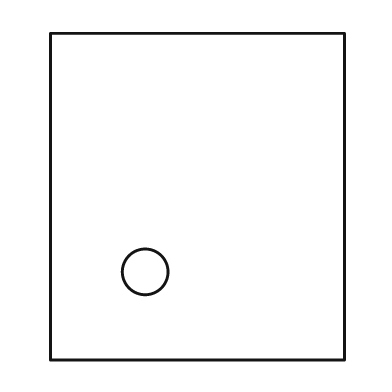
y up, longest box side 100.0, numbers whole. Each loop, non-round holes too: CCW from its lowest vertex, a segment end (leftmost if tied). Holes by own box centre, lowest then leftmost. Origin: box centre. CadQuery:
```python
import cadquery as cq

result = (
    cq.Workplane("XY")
    .moveTo(-45.0, -50.0)
    .lineTo(45.0, -50.0)
    .lineTo(45.0, 50.0)
    .lineTo(-45.0, 50.0)
    .close()
    .moveTo(-16.0, -23.0)
    .circle(7.0)
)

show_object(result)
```